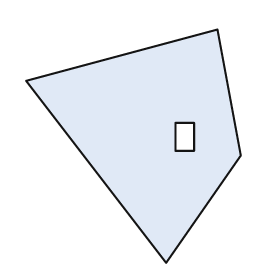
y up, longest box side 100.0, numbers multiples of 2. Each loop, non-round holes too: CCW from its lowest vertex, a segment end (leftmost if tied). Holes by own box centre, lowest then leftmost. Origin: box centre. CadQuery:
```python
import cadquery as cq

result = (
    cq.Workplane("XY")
    .moveTo(14.0, -50.0)
    .lineTo(46.0, -4.0)
    .lineTo(36.0, 50.0)
    .lineTo(-46.0, 28.0)
    .close()
    .moveTo(18.0, -2.0)
    .lineTo(26.0, -2.0)
    .lineTo(26.0, 10.0)
    .lineTo(18.0, 10.0)
    .close()
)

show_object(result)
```